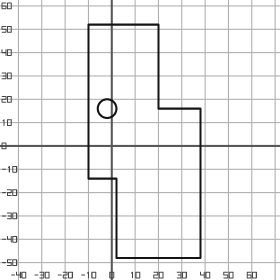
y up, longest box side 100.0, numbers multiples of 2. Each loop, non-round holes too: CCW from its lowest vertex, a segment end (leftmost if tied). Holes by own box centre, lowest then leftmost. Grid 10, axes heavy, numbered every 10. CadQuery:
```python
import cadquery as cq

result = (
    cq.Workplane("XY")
    .moveTo(2.0, -48.0)
    .lineTo(38.0, -48.0)
    .lineTo(38.0, 16.0)
    .lineTo(20.0, 16.0)
    .lineTo(20.0, 52.0)
    .lineTo(-10.0, 52.0)
    .lineTo(-10.0, -14.0)
    .lineTo(2.0, -14.0)
    .close()
    .moveTo(-2.0, 16.0)
    .circle(4.0)
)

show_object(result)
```